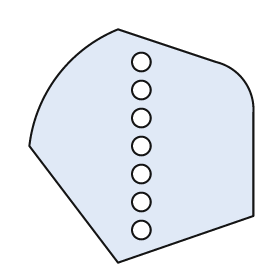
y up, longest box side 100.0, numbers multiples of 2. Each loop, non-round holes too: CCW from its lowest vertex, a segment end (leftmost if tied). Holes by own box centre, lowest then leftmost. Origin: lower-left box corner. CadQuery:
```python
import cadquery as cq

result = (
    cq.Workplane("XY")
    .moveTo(38.0, 0.0)
    .lineTo(96.0, 20.0)
    .lineTo(96.0, 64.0)
    .threePointArc((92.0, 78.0), (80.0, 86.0))
    .lineTo(38.0, 100.0)
    .threePointArc((12.0, 80.0), (0.0, 50.0))
    .close()
    .moveTo(48.0, 14.0)
    .circle(4.0)
    .moveTo(48.0, 26.0)
    .circle(4.0)
    .moveTo(48.0, 38.0)
    .circle(4.0)
    .moveTo(48.0, 50.0)
    .circle(4.0)
    .moveTo(48.0, 62.0)
    .circle(4.0)
    .moveTo(48.0, 74.0)
    .circle(4.0)
    .moveTo(48.0, 86.0)
    .circle(4.0)
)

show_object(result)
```